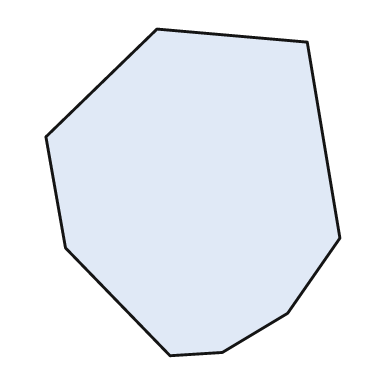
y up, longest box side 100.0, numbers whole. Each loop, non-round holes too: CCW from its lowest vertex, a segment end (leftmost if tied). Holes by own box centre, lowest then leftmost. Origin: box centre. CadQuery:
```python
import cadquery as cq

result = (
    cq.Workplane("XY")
    .moveTo(-7.0, -50.0)
    .lineTo(9.0, -49.0)
    .lineTo(29.0, -37.0)
    .lineTo(45.0, -14.0)
    .lineTo(35.0, 46.0)
    .lineTo(-11.0, 50.0)
    .lineTo(-45.0, 17.0)
    .lineTo(-39.0, -17.0)
    .close()
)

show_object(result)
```